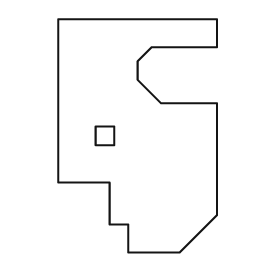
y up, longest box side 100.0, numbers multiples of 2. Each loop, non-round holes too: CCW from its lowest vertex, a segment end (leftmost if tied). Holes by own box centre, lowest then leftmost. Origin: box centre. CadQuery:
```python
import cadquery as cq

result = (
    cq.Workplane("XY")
    .moveTo(-4.0, -50.0)
    .lineTo(18.0, -50.0)
    .lineTo(34.0, -34.0)
    .lineTo(34.0, 14.0)
    .lineTo(10.0, 14.0)
    .lineTo(0.0, 24.0)
    .lineTo(0.0, 32.0)
    .lineTo(6.0, 38.0)
    .lineTo(34.0, 38.0)
    .lineTo(34.0, 50.0)
    .lineTo(-34.0, 50.0)
    .lineTo(-34.0, -20.0)
    .lineTo(-12.0, -20.0)
    .lineTo(-12.0, -38.0)
    .lineTo(-4.0, -38.0)
    .close()
    .moveTo(-18.0, -4.0)
    .lineTo(-10.0, -4.0)
    .lineTo(-10.0, 4.0)
    .lineTo(-18.0, 4.0)
    .close()
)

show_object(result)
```